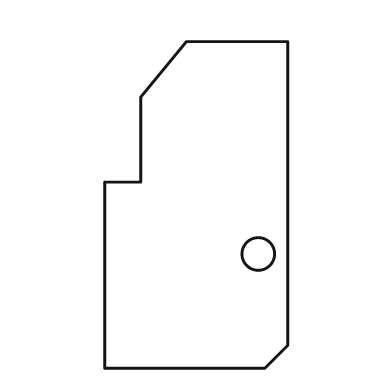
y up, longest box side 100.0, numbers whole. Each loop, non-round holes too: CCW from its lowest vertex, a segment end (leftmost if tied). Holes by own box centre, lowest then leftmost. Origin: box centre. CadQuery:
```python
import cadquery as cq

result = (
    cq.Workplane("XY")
    .moveTo(-28.0, -50.0)
    .lineTo(21.0, -50.0)
    .lineTo(28.0, -43.0)
    .lineTo(28.0, 50.0)
    .lineTo(-3.0, 50.0)
    .lineTo(-17.0, 33.0)
    .lineTo(-17.0, 7.0)
    .lineTo(-28.0, 7.0)
    .close()
    .moveTo(19.0, -15.0)
    .circle(5.0)
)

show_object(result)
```